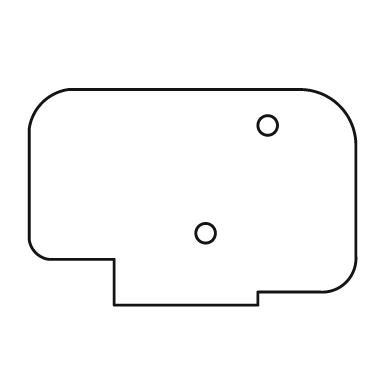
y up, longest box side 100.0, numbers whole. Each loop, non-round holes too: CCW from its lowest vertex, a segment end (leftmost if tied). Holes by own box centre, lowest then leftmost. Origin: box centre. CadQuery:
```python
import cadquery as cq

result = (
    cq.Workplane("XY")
    .moveTo(-24.0, -33.0)
    .lineTo(20.0, -33.0)
    .lineTo(20.0, -29.0)
    .lineTo(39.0, -29.0)
    .threePointArc((47.0, -26.0), (50.0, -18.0))
    .lineTo(50.0, 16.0)
    .threePointArc((45.0, 28.0), (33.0, 33.0))
    .lineTo(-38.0, 33.0)
    .threePointArc((-46.0, 29.0), (-50.0, 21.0))
    .lineTo(-50.0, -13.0)
    .threePointArc((-48.0, -17.0), (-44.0, -19.0))
    .lineTo(-24.0, -19.0)
    .close()
    .moveTo(4.0, -11.0)
    .circle(3.0)
    .moveTo(23.0, 22.0)
    .circle(3.0)
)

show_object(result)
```